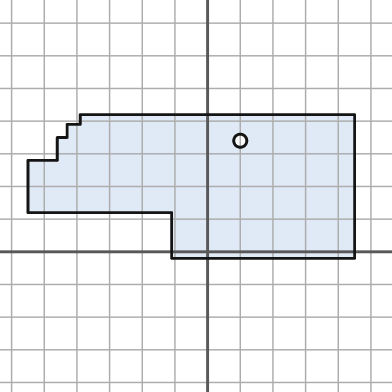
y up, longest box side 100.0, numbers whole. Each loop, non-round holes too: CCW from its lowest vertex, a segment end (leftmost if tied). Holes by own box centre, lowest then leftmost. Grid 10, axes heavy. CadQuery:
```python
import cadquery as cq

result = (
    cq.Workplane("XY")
    .moveTo(-11.0, -2.0)
    .lineTo(45.0, -2.0)
    .lineTo(45.0, 42.0)
    .lineTo(-39.0, 42.0)
    .lineTo(-39.0, 39.0)
    .lineTo(-43.0, 39.0)
    .lineTo(-43.0, 35.0)
    .lineTo(-46.0, 35.0)
    .lineTo(-46.0, 28.0)
    .lineTo(-55.0, 28.0)
    .lineTo(-55.0, 12.0)
    .lineTo(-11.0, 12.0)
    .close()
    .moveTo(10.0, 34.0)
    .circle(2.0)
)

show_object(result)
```